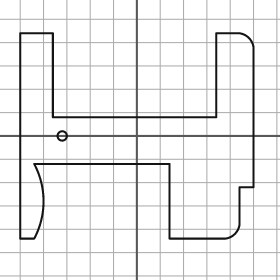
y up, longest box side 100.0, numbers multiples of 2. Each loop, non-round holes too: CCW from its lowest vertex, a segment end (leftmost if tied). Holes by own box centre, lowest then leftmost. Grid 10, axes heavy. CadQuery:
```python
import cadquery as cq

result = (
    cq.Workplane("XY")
    .moveTo(-50.0, -44.0)
    .lineTo(-44.0, -44.0)
    .threePointArc((-40.0, -28.0), (-44.0, -12.0))
    .lineTo(14.0, -12.0)
    .lineTo(14.0, -44.0)
    .lineTo(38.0, -44.0)
    .threePointArc((42.0, -42.0), (44.0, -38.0))
    .lineTo(44.0, -22.0)
    .lineTo(50.0, -22.0)
    .lineTo(50.0, 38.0)
    .threePointArc((48.0, 42.0), (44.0, 44.0))
    .lineTo(34.0, 44.0)
    .lineTo(34.0, 8.0)
    .lineTo(-36.0, 8.0)
    .lineTo(-36.0, 44.0)
    .lineTo(-50.0, 44.0)
    .close()
    .moveTo(-32.0, 0.0)
    .circle(2.0)
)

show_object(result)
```